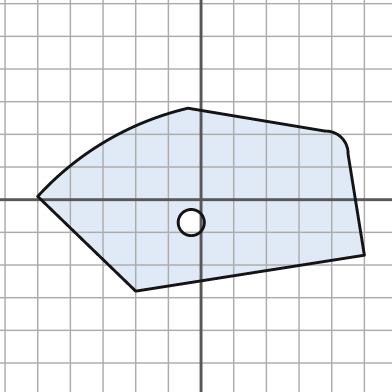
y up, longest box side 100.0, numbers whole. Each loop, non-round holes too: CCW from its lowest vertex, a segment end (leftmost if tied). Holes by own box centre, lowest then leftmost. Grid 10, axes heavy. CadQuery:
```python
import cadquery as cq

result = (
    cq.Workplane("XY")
    .moveTo(-20.0, -28.0)
    .lineTo(50.0, -17.0)
    .lineTo(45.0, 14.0)
    .threePointArc((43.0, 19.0), (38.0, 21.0))
    .lineTo(-4.0, 28.0)
    .threePointArc((-29.0, 18.0), (-50.0, 1.0))
    .close()
    .moveTo(-3.0, -7.0)
    .circle(4.0)
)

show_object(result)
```